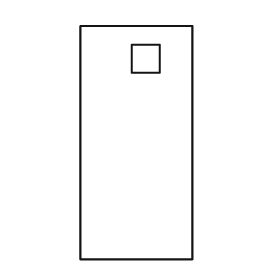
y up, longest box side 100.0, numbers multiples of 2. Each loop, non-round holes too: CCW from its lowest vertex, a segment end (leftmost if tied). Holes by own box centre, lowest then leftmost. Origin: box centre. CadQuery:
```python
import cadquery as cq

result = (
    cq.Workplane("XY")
    .moveTo(-24.0, -50.0)
    .lineTo(24.0, -50.0)
    .lineTo(24.0, 50.0)
    .lineTo(-24.0, 50.0)
    .close()
    .moveTo(-2.0, 30.0)
    .lineTo(10.0, 30.0)
    .lineTo(10.0, 42.0)
    .lineTo(-2.0, 42.0)
    .close()
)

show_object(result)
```